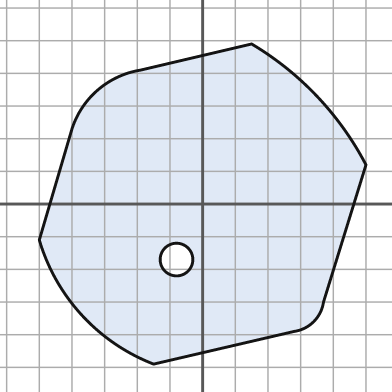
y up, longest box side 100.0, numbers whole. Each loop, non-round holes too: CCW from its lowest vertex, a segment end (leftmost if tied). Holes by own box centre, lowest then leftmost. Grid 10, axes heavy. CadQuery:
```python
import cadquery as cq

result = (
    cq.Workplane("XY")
    .moveTo(-15.0, -49.0)
    .lineTo(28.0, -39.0)
    .threePointArc((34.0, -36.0), (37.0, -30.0))
    .lineTo(50.0, 12.0)
    .threePointArc((35.0, 33.0), (15.0, 49.0))
    .lineTo(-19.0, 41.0)
    .threePointArc((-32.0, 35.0), (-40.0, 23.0))
    .lineTo(-50.0, -11.0)
    .threePointArc((-37.0, -34.0), (-15.0, -49.0))
    .close()
    .moveTo(-8.0, -17.0)
    .circle(5.0)
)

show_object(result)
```